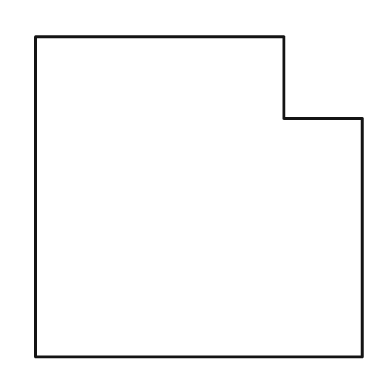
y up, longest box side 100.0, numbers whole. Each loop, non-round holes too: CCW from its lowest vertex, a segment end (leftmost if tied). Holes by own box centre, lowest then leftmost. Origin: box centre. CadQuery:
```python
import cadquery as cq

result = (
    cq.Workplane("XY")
    .moveTo(-50.0, -49.0)
    .lineTo(50.0, -49.0)
    .lineTo(50.0, 24.0)
    .lineTo(26.0, 24.0)
    .lineTo(26.0, 49.0)
    .lineTo(-50.0, 49.0)
    .close()
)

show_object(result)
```